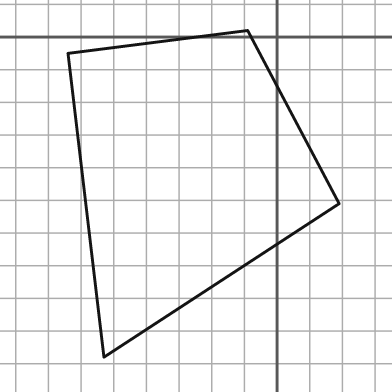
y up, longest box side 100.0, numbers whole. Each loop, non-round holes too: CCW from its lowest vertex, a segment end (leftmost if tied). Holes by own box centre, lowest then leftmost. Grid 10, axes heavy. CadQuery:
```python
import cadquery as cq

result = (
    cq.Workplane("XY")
    .moveTo(-53.0, -98.0)
    .lineTo(19.0, -51.0)
    .lineTo(-9.0, 2.0)
    .lineTo(-64.0, -5.0)
    .close()
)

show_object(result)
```